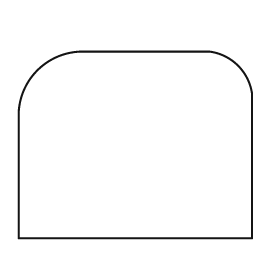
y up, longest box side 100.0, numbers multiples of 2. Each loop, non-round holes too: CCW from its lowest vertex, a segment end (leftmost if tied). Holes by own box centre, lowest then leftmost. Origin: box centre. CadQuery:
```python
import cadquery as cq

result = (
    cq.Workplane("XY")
    .moveTo(-50.0, -40.0)
    .lineTo(50.0, -40.0)
    .lineTo(50.0, 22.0)
    .threePointArc((44.0, 34.0), (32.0, 40.0))
    .lineTo(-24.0, 40.0)
    .threePointArc((-42.0, 32.0), (-50.0, 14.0))
    .close()
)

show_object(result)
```